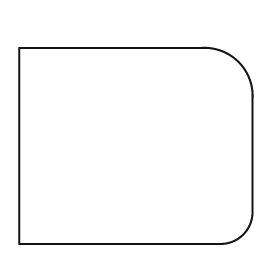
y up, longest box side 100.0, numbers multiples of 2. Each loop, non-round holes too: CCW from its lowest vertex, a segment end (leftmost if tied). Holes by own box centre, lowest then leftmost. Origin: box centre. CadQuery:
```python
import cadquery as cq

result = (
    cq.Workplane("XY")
    .moveTo(-50.0, -42.0)
    .lineTo(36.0, -42.0)
    .threePointArc((46.0, -38.0), (50.0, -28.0))
    .lineTo(50.0, 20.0)
    .threePointArc((44.0, 36.0), (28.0, 42.0))
    .lineTo(-50.0, 42.0)
    .close()
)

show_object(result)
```